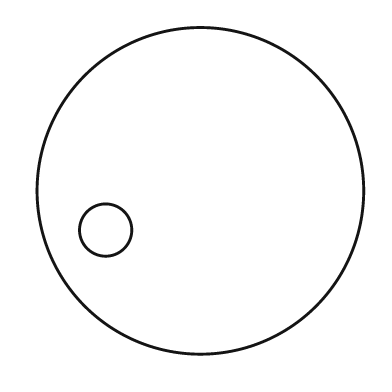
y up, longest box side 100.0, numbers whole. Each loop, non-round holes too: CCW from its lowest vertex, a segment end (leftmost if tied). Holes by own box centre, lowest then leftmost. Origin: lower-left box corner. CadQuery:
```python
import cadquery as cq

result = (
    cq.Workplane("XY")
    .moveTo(50.0, 50.0)
    .circle(50.0)
    .moveTo(21.0, 38.0)
    .circle(8.0)
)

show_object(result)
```